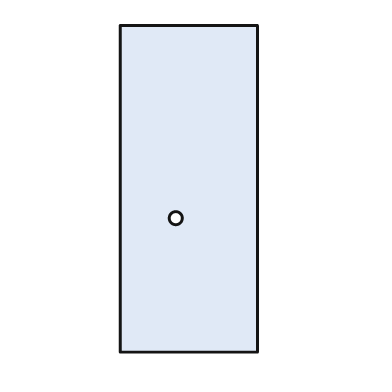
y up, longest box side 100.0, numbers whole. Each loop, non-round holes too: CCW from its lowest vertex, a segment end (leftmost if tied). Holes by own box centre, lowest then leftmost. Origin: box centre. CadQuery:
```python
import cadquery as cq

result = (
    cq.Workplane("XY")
    .moveTo(-21.0, -50.0)
    .lineTo(21.0, -50.0)
    .lineTo(21.0, 50.0)
    .lineTo(-21.0, 50.0)
    .close()
    .moveTo(-4.0, -9.0)
    .circle(2.0)
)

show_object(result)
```